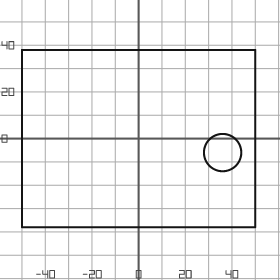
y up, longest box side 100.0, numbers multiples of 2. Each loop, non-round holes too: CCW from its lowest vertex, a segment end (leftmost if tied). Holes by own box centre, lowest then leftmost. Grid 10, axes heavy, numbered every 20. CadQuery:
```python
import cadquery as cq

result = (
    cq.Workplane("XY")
    .moveTo(-50.0, -38.0)
    .lineTo(50.0, -38.0)
    .lineTo(50.0, 38.0)
    .lineTo(-50.0, 38.0)
    .close()
    .moveTo(36.0, -6.0)
    .circle(8.0)
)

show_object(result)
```